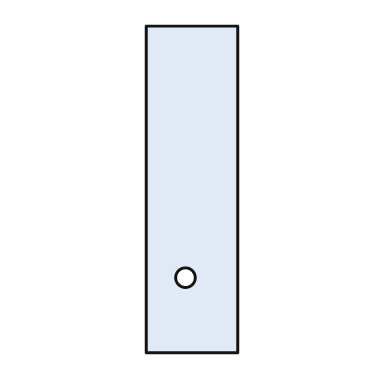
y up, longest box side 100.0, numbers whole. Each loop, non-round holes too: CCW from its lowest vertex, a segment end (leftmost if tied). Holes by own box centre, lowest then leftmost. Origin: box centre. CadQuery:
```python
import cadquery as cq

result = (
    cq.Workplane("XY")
    .moveTo(-14.0, -50.0)
    .lineTo(14.0, -50.0)
    .lineTo(14.0, 50.0)
    .lineTo(-14.0, 50.0)
    .close()
    .moveTo(-2.0, -27.0)
    .circle(3.0)
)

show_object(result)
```